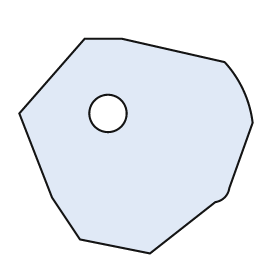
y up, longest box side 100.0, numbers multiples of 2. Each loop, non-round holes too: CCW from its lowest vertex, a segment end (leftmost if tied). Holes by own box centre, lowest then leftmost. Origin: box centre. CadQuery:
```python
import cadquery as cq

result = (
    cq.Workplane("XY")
    .moveTo(6.0, -46.0)
    .lineTo(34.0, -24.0)
    .threePointArc((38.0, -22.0), (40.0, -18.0))
    .lineTo(50.0, 10.0)
    .threePointArc((46.0, 24.0), (38.0, 36.0))
    .lineTo(-6.0, 46.0)
    .lineTo(-22.0, 46.0)
    .lineTo(-50.0, 14.0)
    .lineTo(-36.0, -22.0)
    .lineTo(-24.0, -40.0)
    .close()
    .moveTo(-12.0, 14.0)
    .circle(8.0)
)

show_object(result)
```